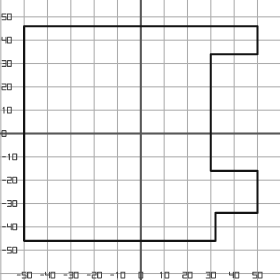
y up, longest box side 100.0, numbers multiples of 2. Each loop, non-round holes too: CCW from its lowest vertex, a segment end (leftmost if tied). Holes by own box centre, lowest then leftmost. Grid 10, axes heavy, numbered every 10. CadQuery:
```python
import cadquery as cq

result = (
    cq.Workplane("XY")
    .moveTo(-50.0, -46.0)
    .lineTo(32.0, -46.0)
    .lineTo(32.0, -34.0)
    .lineTo(50.0, -34.0)
    .lineTo(50.0, -16.0)
    .lineTo(30.0, -16.0)
    .lineTo(30.0, 34.0)
    .lineTo(50.0, 34.0)
    .lineTo(50.0, 46.0)
    .lineTo(-50.0, 46.0)
    .close()
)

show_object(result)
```